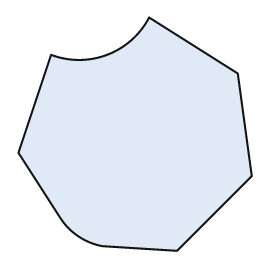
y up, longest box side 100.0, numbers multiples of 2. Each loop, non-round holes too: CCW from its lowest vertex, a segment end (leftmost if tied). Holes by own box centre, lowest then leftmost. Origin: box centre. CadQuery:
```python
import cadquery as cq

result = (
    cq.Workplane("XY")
    .moveTo(18.0, -50.0)
    .lineTo(50.0, -18.0)
    .lineTo(44.0, 26.0)
    .lineTo(6.0, 50.0)
    .threePointArc((-12.0, 34.0), (-36.0, 34.0))
    .lineTo(-50.0, -8.0)
    .lineTo(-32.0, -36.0)
    .threePointArc((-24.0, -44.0), (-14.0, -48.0))
    .close()
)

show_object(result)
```